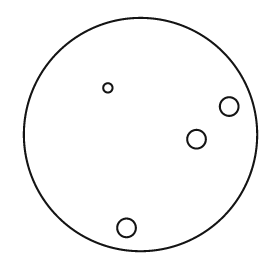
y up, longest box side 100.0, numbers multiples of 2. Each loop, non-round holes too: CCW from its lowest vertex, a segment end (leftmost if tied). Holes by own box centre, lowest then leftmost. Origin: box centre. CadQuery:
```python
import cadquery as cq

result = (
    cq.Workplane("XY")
    .moveTo(0.0, 0.0)
    .circle(50.0)
    .moveTo(-6.0, -40.0)
    .circle(4.0)
    .moveTo(24.0, -2.0)
    .circle(4.0)
    .moveTo(38.0, 12.0)
    .circle(4.0)
    .moveTo(-14.0, 20.0)
    .circle(2.0)
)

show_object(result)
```